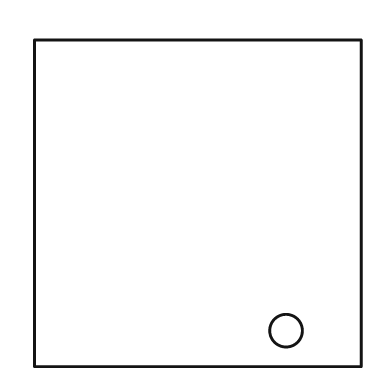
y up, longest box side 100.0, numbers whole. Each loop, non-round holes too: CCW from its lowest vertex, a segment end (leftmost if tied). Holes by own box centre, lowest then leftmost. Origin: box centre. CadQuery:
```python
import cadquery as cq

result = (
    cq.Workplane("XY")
    .moveTo(-50.0, -50.0)
    .lineTo(50.0, -50.0)
    .lineTo(50.0, 50.0)
    .lineTo(-50.0, 50.0)
    .close()
    .moveTo(27.0, -39.0)
    .circle(5.0)
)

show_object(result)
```